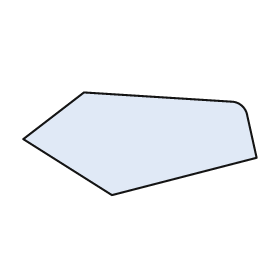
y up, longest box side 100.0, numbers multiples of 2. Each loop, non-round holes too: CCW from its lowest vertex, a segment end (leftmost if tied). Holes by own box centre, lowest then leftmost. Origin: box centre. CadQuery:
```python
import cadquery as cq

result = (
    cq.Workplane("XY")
    .moveTo(-12.0, -22.0)
    .lineTo(50.0, -6.0)
    .lineTo(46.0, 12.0)
    .threePointArc((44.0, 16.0), (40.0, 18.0))
    .lineTo(-24.0, 22.0)
    .lineTo(-50.0, 2.0)
    .close()
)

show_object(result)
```